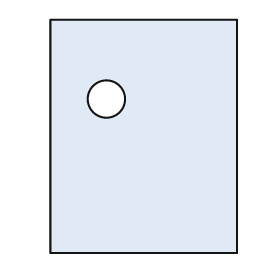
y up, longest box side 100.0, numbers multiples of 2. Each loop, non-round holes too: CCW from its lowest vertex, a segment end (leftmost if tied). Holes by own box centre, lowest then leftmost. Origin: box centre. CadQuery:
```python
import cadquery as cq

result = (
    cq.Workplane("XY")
    .moveTo(-40.0, -50.0)
    .lineTo(40.0, -50.0)
    .lineTo(40.0, 50.0)
    .lineTo(-40.0, 50.0)
    .close()
    .moveTo(-16.0, 16.0)
    .circle(8.0)
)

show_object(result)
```